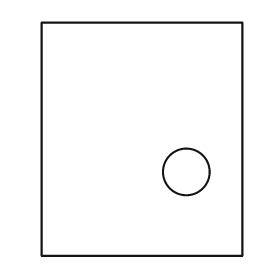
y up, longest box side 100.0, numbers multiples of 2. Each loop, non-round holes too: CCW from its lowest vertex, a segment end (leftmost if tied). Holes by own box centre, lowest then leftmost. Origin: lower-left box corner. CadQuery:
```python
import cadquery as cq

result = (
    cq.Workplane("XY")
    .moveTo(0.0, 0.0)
    .lineTo(86.0, 0.0)
    .lineTo(86.0, 100.0)
    .lineTo(0.0, 100.0)
    .close()
    .moveTo(62.0, 36.0)
    .circle(10.0)
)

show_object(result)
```